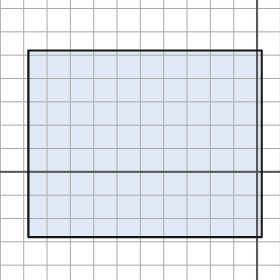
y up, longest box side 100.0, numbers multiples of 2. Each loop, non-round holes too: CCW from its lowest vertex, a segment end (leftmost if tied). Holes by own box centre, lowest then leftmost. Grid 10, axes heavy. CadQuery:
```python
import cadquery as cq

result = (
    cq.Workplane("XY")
    .moveTo(-98.0, -28.0)
    .lineTo(2.0, -28.0)
    .lineTo(2.0, 52.0)
    .lineTo(-98.0, 52.0)
    .close()
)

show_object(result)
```